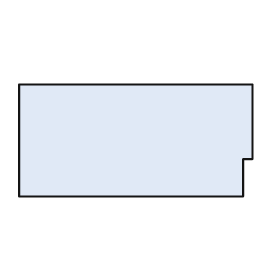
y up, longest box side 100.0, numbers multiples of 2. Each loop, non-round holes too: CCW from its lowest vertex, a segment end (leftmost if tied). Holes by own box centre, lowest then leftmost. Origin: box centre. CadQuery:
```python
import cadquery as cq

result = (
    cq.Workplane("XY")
    .moveTo(-50.0, -24.0)
    .lineTo(46.0, -24.0)
    .lineTo(46.0, -8.0)
    .lineTo(50.0, -8.0)
    .lineTo(50.0, 24.0)
    .lineTo(-50.0, 24.0)
    .close()
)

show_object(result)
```